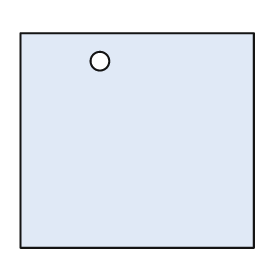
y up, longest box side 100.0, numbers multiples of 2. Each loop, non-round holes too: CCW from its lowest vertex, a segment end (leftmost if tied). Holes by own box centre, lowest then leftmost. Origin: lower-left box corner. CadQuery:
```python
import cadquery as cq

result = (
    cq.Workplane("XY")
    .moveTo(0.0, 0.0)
    .lineTo(100.0, 0.0)
    .lineTo(100.0, 92.0)
    .lineTo(0.0, 92.0)
    .close()
    .moveTo(34.0, 80.0)
    .circle(4.0)
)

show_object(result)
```